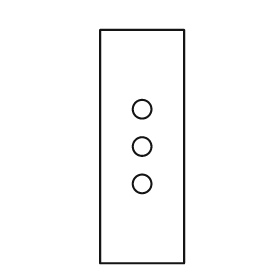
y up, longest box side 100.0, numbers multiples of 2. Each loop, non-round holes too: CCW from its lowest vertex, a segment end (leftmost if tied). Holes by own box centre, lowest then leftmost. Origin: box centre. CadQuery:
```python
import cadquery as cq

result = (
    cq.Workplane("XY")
    .moveTo(-18.0, -50.0)
    .lineTo(18.0, -50.0)
    .lineTo(18.0, 50.0)
    .lineTo(-18.0, 50.0)
    .close()
    .moveTo(0.0, -16.0)
    .circle(4.0)
    .moveTo(0.0, 0.0)
    .circle(4.0)
    .moveTo(0.0, 16.0)
    .circle(4.0)
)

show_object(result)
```